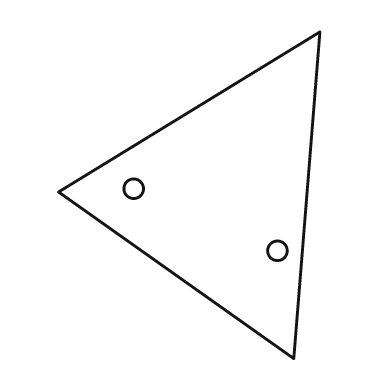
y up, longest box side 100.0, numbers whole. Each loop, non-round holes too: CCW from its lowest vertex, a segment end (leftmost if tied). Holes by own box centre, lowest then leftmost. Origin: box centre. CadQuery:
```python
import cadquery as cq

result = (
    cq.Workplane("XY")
    .moveTo(32.0, -50.0)
    .lineTo(40.0, 50.0)
    .lineTo(-40.0, 1.0)
    .close()
    .moveTo(27.0, -17.0)
    .circle(3.0)
    .moveTo(-17.0, 2.0)
    .circle(3.0)
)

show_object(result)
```